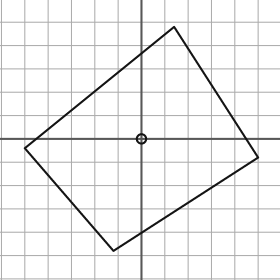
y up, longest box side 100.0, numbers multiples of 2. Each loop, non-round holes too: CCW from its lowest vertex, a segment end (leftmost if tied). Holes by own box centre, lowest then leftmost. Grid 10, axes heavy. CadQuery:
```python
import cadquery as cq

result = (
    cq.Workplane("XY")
    .moveTo(-12.0, -48.0)
    .lineTo(50.0, -8.0)
    .lineTo(14.0, 48.0)
    .lineTo(-50.0, -4.0)
    .close()
    .moveTo(0.0, 0.0)
    .circle(2.0)
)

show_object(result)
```